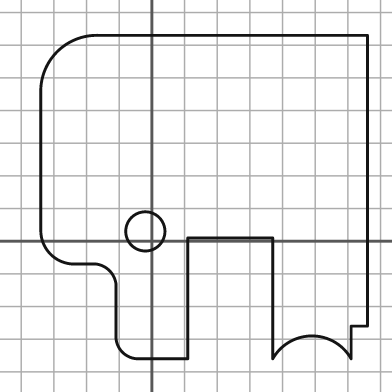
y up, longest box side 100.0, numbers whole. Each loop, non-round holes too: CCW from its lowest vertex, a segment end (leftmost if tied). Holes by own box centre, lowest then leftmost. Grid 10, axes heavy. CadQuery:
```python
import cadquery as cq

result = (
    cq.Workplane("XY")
    .moveTo(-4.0, -36.0)
    .lineTo(11.0, -36.0)
    .lineTo(11.0, 1.0)
    .lineTo(37.0, 1.0)
    .lineTo(37.0, -36.0)
    .threePointArc((49.0, -29.0), (61.0, -36.0))
    .lineTo(61.0, -26.0)
    .lineTo(66.0, -26.0)
    .lineTo(66.0, 63.0)
    .lineTo(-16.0, 63.0)
    .threePointArc((-29.0, 58.0), (-34.0, 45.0))
    .lineTo(-34.0, 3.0)
    .threePointArc((-31.0, -4.0), (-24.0, -7.0))
    .lineTo(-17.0, -7.0)
    .threePointArc((-13.0, -9.0), (-11.0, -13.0))
    .lineTo(-11.0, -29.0)
    .threePointArc((-9.0, -34.0), (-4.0, -36.0))
    .close()
    .moveTo(-2.0, 3.0)
    .circle(6.0)
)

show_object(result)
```